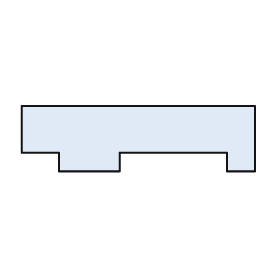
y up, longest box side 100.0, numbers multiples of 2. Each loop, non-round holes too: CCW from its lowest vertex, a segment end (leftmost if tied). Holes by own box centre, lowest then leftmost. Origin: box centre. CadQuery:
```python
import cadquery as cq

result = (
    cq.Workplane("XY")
    .moveTo(-34.0, -14.0)
    .lineTo(-8.0, -14.0)
    .lineTo(-8.0, -6.0)
    .lineTo(38.0, -6.0)
    .lineTo(38.0, -14.0)
    .lineTo(50.0, -14.0)
    .lineTo(50.0, 14.0)
    .lineTo(-50.0, 14.0)
    .lineTo(-50.0, -6.0)
    .lineTo(-34.0, -6.0)
    .close()
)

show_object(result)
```